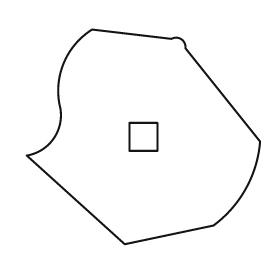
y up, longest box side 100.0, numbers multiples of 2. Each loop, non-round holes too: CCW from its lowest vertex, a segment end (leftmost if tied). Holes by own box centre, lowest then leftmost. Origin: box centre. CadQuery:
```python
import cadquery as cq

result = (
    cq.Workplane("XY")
    .moveTo(-8.0, -46.0)
    .lineTo(30.0, -38.0)
    .threePointArc((44.0, -22.0), (50.0, -2.0))
    .lineTo(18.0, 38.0)
    .threePointArc((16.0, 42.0), (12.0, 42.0))
    .lineTo(-22.0, 46.0)
    .threePointArc((-34.0, 32.0), (-36.0, 14.0))
    .threePointArc((-38.0, 0.0), (-50.0, -8.0))
    .close()
    .moveTo(-6.0, -6.0)
    .lineTo(6.0, -6.0)
    .lineTo(6.0, 6.0)
    .lineTo(-6.0, 6.0)
    .close()
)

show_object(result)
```